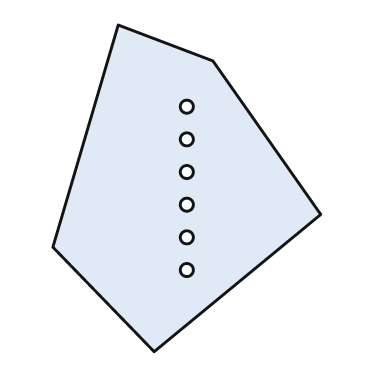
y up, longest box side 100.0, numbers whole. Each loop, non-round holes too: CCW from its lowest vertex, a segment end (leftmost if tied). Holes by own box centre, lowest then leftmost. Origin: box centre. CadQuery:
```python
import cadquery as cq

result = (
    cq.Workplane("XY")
    .moveTo(-10.0, -50.0)
    .lineTo(41.0, -8.0)
    .lineTo(8.0, 39.0)
    .lineTo(-21.0, 50.0)
    .lineTo(-41.0, -18.0)
    .close()
    .moveTo(0.0, -25.0)
    .circle(2.0)
    .moveTo(0.0, -15.0)
    .circle(2.0)
    .moveTo(0.0, -5.0)
    .circle(2.0)
    .moveTo(0.0, 5.0)
    .circle(2.0)
    .moveTo(0.0, 15.0)
    .circle(2.0)
    .moveTo(0.0, 25.0)
    .circle(2.0)
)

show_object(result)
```